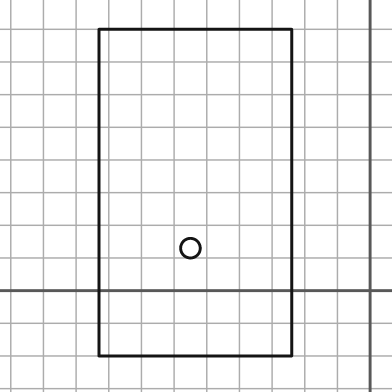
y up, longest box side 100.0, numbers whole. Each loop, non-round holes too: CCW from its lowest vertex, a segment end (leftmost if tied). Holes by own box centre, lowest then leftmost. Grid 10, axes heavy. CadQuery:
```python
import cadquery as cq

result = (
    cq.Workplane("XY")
    .moveTo(-83.0, -20.0)
    .lineTo(-24.0, -20.0)
    .lineTo(-24.0, 80.0)
    .lineTo(-83.0, 80.0)
    .close()
    .moveTo(-55.0, 13.0)
    .circle(3.0)
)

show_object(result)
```